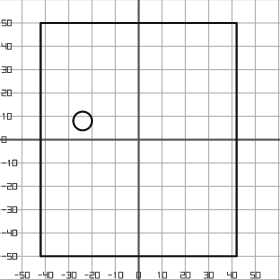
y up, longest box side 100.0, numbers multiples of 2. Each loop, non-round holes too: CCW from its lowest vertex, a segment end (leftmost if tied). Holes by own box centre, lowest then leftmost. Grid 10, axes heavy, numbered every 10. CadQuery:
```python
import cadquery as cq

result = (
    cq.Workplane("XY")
    .moveTo(-42.0, -50.0)
    .lineTo(42.0, -50.0)
    .lineTo(42.0, 50.0)
    .lineTo(-42.0, 50.0)
    .close()
    .moveTo(-24.0, 8.0)
    .circle(4.0)
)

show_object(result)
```